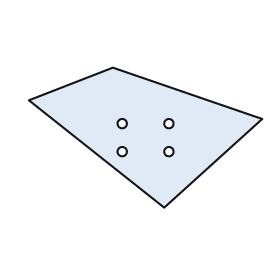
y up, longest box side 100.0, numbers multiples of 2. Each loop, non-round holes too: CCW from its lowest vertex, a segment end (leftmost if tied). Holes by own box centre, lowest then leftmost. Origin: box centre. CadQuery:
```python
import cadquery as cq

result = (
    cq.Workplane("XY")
    .moveTo(8.0, -30.0)
    .lineTo(50.0, 8.0)
    .lineTo(-14.0, 30.0)
    .lineTo(-50.0, 16.0)
    .close()
    .moveTo(-10.0, -6.0)
    .circle(2.0)
    .moveTo(10.0, -6.0)
    .circle(2.0)
    .moveTo(-10.0, 6.0)
    .circle(2.0)
    .moveTo(10.0, 6.0)
    .circle(2.0)
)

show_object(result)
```